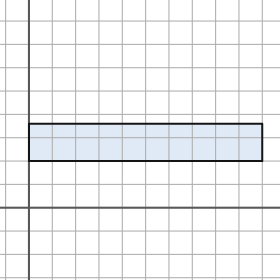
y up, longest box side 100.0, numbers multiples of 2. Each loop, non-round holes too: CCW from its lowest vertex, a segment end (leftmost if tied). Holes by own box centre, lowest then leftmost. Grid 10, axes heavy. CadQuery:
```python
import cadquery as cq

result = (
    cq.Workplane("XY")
    .moveTo(0.0, 20.0)
    .lineTo(100.0, 20.0)
    .lineTo(100.0, 36.0)
    .lineTo(0.0, 36.0)
    .close()
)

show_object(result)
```